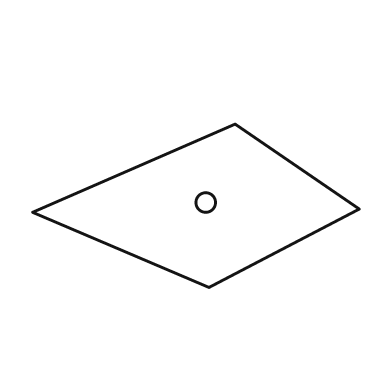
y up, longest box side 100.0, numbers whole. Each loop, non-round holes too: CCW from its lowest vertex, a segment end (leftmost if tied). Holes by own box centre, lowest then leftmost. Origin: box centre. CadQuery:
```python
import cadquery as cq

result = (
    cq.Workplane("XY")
    .moveTo(4.0, -25.0)
    .lineTo(50.0, -1.0)
    .lineTo(12.0, 25.0)
    .lineTo(-50.0, -2.0)
    .close()
    .moveTo(3.0, 1.0)
    .circle(3.0)
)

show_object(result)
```